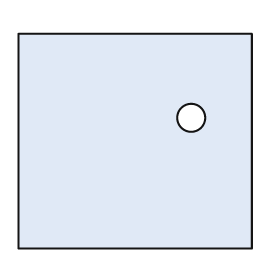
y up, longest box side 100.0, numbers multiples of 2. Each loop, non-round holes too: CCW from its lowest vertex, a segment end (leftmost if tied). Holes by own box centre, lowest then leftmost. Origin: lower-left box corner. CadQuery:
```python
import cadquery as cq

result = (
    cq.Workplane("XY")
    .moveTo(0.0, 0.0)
    .lineTo(100.0, 0.0)
    .lineTo(100.0, 92.0)
    .lineTo(0.0, 92.0)
    .close()
    .moveTo(74.0, 56.0)
    .circle(6.0)
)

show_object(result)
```